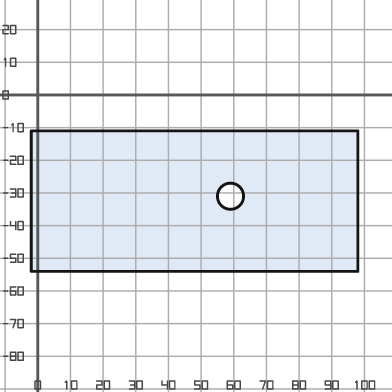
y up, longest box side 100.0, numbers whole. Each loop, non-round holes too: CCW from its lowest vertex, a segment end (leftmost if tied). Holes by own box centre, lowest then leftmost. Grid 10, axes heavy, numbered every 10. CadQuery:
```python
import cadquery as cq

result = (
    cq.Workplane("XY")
    .moveTo(-2.0, -54.0)
    .lineTo(98.0, -54.0)
    .lineTo(98.0, -11.0)
    .lineTo(-2.0, -11.0)
    .close()
    .moveTo(59.0, -31.0)
    .circle(4.0)
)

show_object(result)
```